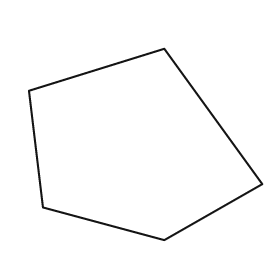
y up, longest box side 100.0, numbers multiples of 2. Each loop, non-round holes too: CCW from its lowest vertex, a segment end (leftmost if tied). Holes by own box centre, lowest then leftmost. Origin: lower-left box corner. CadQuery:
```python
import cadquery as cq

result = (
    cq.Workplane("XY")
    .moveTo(58.0, 0.0)
    .lineTo(100.0, 24.0)
    .lineTo(58.0, 82.0)
    .lineTo(0.0, 64.0)
    .lineTo(6.0, 14.0)
    .close()
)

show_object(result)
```